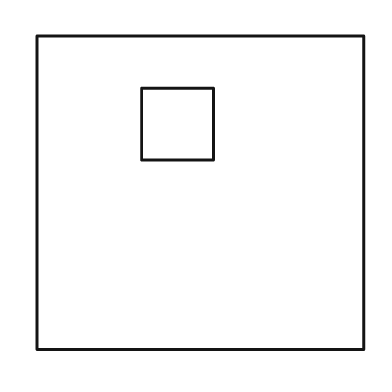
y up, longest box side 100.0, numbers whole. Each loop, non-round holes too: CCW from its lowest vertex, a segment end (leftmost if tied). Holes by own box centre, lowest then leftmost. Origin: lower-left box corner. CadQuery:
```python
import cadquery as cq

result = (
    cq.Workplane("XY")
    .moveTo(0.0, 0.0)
    .lineTo(100.0, 0.0)
    .lineTo(100.0, 96.0)
    .lineTo(0.0, 96.0)
    .close()
    .moveTo(32.0, 58.0)
    .lineTo(54.0, 58.0)
    .lineTo(54.0, 80.0)
    .lineTo(32.0, 80.0)
    .close()
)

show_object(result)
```